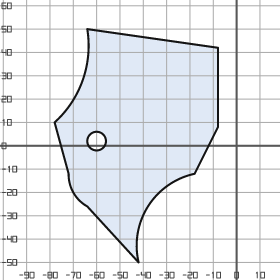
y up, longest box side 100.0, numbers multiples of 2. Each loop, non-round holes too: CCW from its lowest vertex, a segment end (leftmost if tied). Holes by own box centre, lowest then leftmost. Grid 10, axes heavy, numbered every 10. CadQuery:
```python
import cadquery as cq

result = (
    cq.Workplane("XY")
    .moveTo(-42.0, -50.0)
    .threePointArc((-38.0, -26.0), (-18.0, -12.0))
    .lineTo(-8.0, 8.0)
    .lineTo(-8.0, 42.0)
    .lineTo(-64.0, 50.0)
    .threePointArc((-66.0, 28.0), (-78.0, 10.0))
    .lineTo(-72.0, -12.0)
    .threePointArc((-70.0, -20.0), (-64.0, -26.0))
    .close()
    .moveTo(-60.0, 2.0)
    .circle(4.0)
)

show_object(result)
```